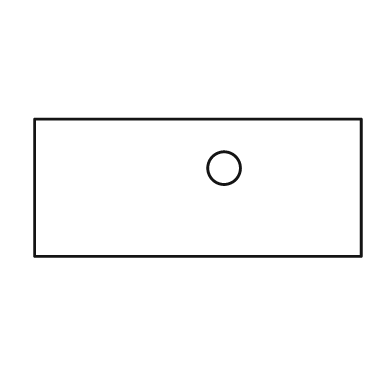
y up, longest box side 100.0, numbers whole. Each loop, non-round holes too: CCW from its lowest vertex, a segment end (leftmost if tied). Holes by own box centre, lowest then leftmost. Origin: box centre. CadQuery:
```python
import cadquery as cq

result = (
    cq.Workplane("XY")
    .moveTo(-50.0, -21.0)
    .lineTo(50.0, -21.0)
    .lineTo(50.0, 21.0)
    .lineTo(-50.0, 21.0)
    .close()
    .moveTo(8.0, 6.0)
    .circle(5.0)
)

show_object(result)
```